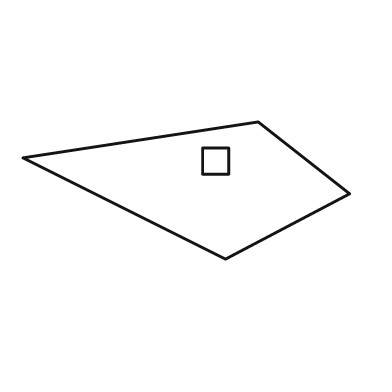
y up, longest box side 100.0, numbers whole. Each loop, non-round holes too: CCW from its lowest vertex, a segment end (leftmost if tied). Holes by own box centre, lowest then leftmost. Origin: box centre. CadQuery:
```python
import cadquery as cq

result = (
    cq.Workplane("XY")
    .moveTo(12.0, -21.0)
    .lineTo(50.0, -1.0)
    .lineTo(22.0, 21.0)
    .lineTo(-50.0, 10.0)
    .close()
    .moveTo(5.0, 5.0)
    .lineTo(13.0, 5.0)
    .lineTo(13.0, 13.0)
    .lineTo(5.0, 13.0)
    .close()
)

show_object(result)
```